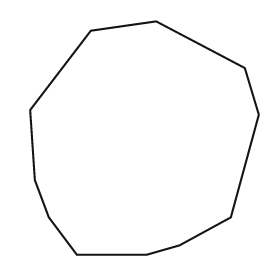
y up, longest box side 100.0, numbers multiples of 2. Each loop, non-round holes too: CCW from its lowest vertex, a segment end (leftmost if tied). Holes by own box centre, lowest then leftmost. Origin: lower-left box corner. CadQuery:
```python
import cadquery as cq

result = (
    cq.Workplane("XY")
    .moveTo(20.0, 0.0)
    .lineTo(50.0, 0.0)
    .lineTo(64.0, 4.0)
    .lineTo(86.0, 16.0)
    .lineTo(98.0, 60.0)
    .lineTo(92.0, 80.0)
    .lineTo(54.0, 100.0)
    .lineTo(26.0, 96.0)
    .lineTo(0.0, 62.0)
    .lineTo(2.0, 32.0)
    .lineTo(8.0, 16.0)
    .close()
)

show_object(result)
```